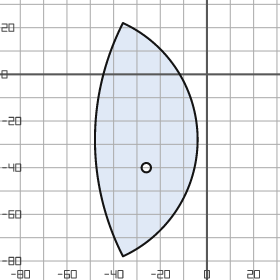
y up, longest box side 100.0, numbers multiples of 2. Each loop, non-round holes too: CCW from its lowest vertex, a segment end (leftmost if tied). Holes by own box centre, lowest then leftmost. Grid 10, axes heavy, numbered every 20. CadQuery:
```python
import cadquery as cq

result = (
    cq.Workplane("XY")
    .moveTo(-36.0, -78.0)
    .threePointArc((-4.0, -28.0), (-36.0, 22.0))
    .threePointArc((-48.0, -28.0), (-36.0, -78.0))
    .close()
    .moveTo(-26.0, -40.0)
    .circle(2.0)
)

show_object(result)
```